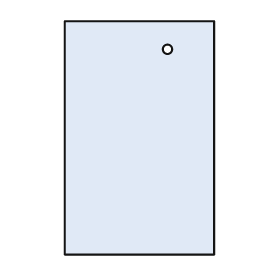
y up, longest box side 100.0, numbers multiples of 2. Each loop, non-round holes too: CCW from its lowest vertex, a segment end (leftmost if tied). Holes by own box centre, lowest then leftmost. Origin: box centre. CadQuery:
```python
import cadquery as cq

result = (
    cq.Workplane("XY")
    .moveTo(-32.0, -50.0)
    .lineTo(32.0, -50.0)
    .lineTo(32.0, 50.0)
    .lineTo(-32.0, 50.0)
    .close()
    .moveTo(12.0, 38.0)
    .circle(2.0)
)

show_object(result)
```